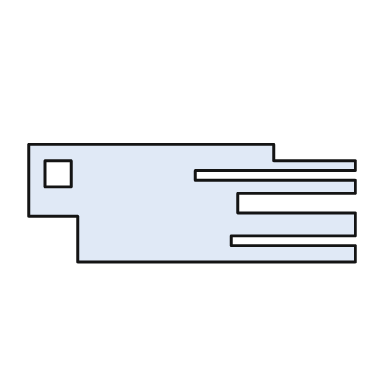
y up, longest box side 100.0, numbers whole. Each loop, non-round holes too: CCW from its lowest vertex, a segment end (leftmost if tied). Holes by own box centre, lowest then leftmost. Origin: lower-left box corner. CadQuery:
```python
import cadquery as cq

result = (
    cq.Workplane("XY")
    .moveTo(15.0, 0.0)
    .lineTo(100.0, 0.0)
    .lineTo(100.0, 5.0)
    .lineTo(62.0, 5.0)
    .lineTo(62.0, 8.0)
    .lineTo(100.0, 8.0)
    .lineTo(100.0, 15.0)
    .lineTo(64.0, 15.0)
    .lineTo(64.0, 21.0)
    .lineTo(100.0, 21.0)
    .lineTo(100.0, 25.0)
    .lineTo(51.0, 25.0)
    .lineTo(51.0, 28.0)
    .lineTo(100.0, 28.0)
    .lineTo(100.0, 31.0)
    .lineTo(75.0, 31.0)
    .lineTo(75.0, 36.0)
    .lineTo(0.0, 36.0)
    .lineTo(0.0, 14.0)
    .lineTo(15.0, 14.0)
    .close()
    .moveTo(5.0, 23.0)
    .lineTo(13.0, 23.0)
    .lineTo(13.0, 31.0)
    .lineTo(5.0, 31.0)
    .close()
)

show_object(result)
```